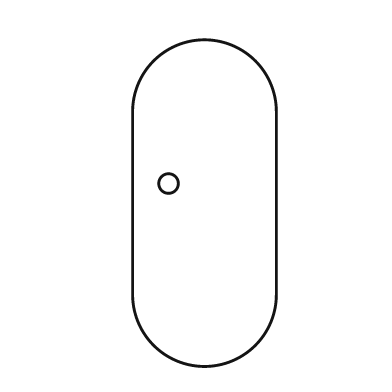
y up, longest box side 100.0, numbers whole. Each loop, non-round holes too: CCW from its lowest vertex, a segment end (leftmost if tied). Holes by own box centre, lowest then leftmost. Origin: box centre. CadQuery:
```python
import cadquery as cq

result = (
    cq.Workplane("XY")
    .moveTo(-22.0, -28.0)
    .threePointArc((0.0, -50.0), (22.0, -28.0))
    .lineTo(22.0, 28.0)
    .threePointArc((0.0, 50.0), (-22.0, 28.0))
    .close()
    .moveTo(-11.0, 6.0)
    .circle(3.0)
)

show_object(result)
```